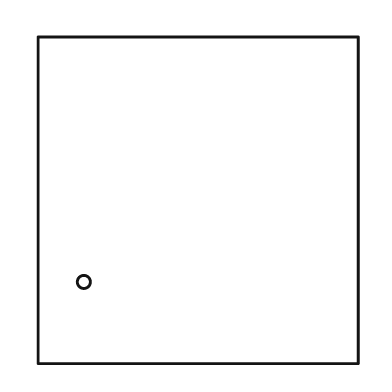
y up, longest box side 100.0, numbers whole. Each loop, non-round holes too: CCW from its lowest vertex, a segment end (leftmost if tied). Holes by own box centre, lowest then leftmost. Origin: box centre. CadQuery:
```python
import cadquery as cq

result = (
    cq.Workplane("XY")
    .moveTo(-49.0, -50.0)
    .lineTo(49.0, -50.0)
    .lineTo(49.0, 50.0)
    .lineTo(-49.0, 50.0)
    .close()
    .moveTo(-35.0, -25.0)
    .circle(2.0)
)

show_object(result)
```